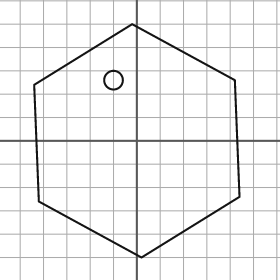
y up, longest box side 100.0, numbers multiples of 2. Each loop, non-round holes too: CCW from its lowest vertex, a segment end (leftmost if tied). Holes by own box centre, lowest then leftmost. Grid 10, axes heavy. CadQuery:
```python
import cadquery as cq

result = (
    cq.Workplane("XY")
    .moveTo(2.0, -50.0)
    .lineTo(44.0, -24.0)
    .lineTo(42.0, 26.0)
    .lineTo(-2.0, 50.0)
    .lineTo(-44.0, 24.0)
    .lineTo(-42.0, -26.0)
    .close()
    .moveTo(-10.0, 26.0)
    .circle(4.0)
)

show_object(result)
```